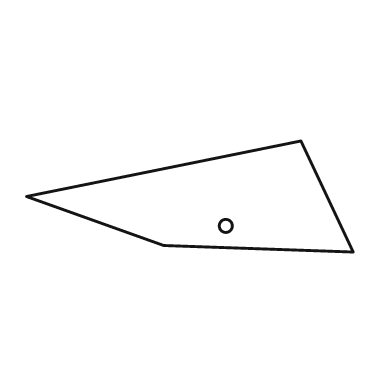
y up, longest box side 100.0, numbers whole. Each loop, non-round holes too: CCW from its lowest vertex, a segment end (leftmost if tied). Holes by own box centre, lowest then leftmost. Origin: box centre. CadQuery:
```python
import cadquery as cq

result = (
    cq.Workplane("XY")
    .moveTo(50.0, -17.0)
    .lineTo(34.0, 17.0)
    .lineTo(-50.0, 0.0)
    .lineTo(-8.0, -15.0)
    .close()
    .moveTo(11.0, -9.0)
    .circle(2.0)
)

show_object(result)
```